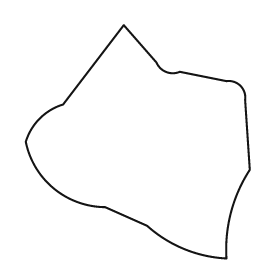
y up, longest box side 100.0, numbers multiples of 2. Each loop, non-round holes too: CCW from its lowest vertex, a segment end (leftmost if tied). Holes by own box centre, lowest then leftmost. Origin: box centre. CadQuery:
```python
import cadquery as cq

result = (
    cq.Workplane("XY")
    .moveTo(38.0, -50.0)
    .threePointArc((40.0, -30.0), (48.0, -12.0))
    .lineTo(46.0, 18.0)
    .threePointArc((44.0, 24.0), (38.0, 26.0))
    .lineTo(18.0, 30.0)
    .threePointArc((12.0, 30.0), (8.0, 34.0))
    .lineTo(-6.0, 50.0)
    .lineTo(-32.0, 16.0)
    .threePointArc((-42.0, 10.0), (-48.0, 0.0))
    .threePointArc((-36.0, -20.0), (-14.0, -28.0))
    .lineTo(4.0, -36.0)
    .threePointArc((20.0, -46.0), (38.0, -50.0))
    .close()
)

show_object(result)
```